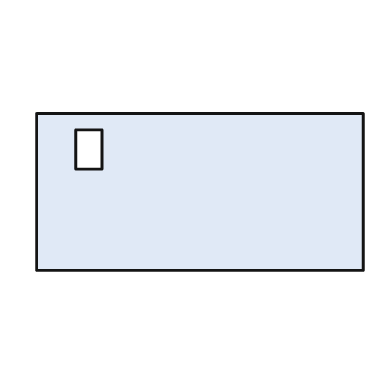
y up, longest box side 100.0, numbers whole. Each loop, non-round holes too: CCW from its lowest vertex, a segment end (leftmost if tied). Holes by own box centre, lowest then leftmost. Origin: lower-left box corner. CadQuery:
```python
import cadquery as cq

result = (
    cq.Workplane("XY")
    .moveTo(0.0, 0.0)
    .lineTo(100.0, 0.0)
    .lineTo(100.0, 48.0)
    .lineTo(0.0, 48.0)
    .close()
    .moveTo(12.0, 31.0)
    .lineTo(20.0, 31.0)
    .lineTo(20.0, 43.0)
    .lineTo(12.0, 43.0)
    .close()
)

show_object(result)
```